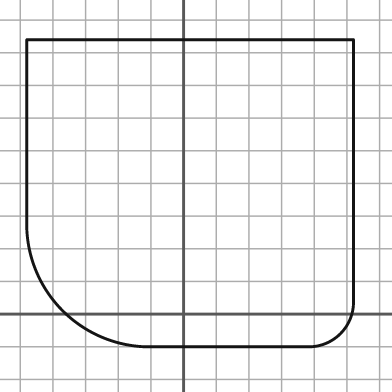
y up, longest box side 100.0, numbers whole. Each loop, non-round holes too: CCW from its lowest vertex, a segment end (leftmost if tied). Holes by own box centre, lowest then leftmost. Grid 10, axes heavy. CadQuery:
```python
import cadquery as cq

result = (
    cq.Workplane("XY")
    .moveTo(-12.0, -10.0)
    .lineTo(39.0, -10.0)
    .threePointArc((48.0, -6.0), (52.0, 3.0))
    .lineTo(52.0, 84.0)
    .lineTo(-48.0, 84.0)
    .lineTo(-48.0, 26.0)
    .threePointArc((-37.0, 1.0), (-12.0, -10.0))
    .close()
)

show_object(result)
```